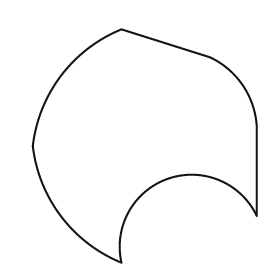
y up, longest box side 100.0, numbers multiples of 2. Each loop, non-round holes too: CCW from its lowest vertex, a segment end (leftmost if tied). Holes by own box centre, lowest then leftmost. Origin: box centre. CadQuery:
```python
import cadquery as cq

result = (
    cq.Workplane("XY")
    .moveTo(-10.0, -50.0)
    .threePointArc((10.0, -14.0), (48.0, -30.0))
    .lineTo(48.0, 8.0)
    .threePointArc((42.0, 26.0), (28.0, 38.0))
    .lineTo(-10.0, 50.0)
    .threePointArc((-36.0, 30.0), (-48.0, 0.0))
    .threePointArc((-36.0, -30.0), (-10.0, -50.0))
    .close()
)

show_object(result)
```